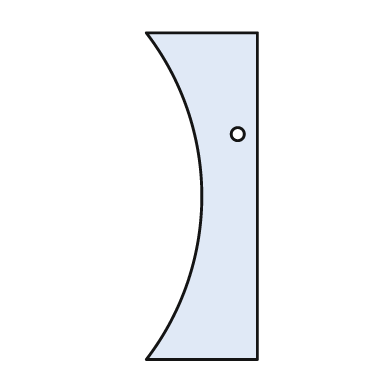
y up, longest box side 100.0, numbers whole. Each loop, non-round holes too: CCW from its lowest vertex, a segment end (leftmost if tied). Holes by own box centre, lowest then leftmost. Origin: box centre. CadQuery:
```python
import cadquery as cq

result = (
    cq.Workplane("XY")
    .moveTo(-17.0, -50.0)
    .lineTo(17.0, -50.0)
    .lineTo(17.0, 50.0)
    .lineTo(-17.0, 50.0)
    .threePointArc((0.0, 0.0), (-17.0, -50.0))
    .close()
    .moveTo(11.0, 19.0)
    .circle(2.0)
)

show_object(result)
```